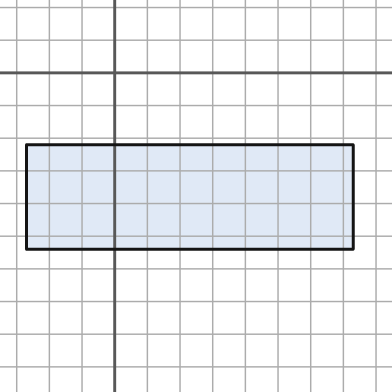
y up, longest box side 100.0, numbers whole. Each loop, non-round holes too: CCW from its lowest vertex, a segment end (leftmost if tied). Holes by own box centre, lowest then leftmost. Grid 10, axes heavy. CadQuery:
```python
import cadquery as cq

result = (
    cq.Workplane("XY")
    .moveTo(-27.0, -54.0)
    .lineTo(73.0, -54.0)
    .lineTo(73.0, -22.0)
    .lineTo(-27.0, -22.0)
    .close()
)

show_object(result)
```